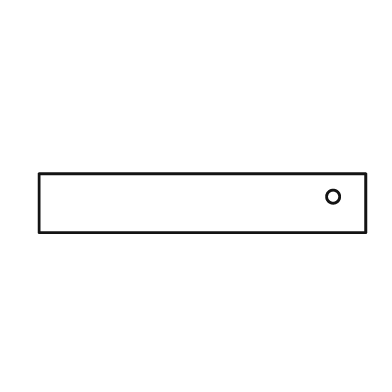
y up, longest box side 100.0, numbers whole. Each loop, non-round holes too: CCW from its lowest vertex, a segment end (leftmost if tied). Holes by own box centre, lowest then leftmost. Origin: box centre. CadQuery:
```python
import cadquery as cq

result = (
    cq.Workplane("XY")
    .moveTo(-50.0, -9.0)
    .lineTo(50.0, -9.0)
    .lineTo(50.0, 9.0)
    .lineTo(-50.0, 9.0)
    .close()
    .moveTo(40.0, 2.0)
    .circle(2.0)
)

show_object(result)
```